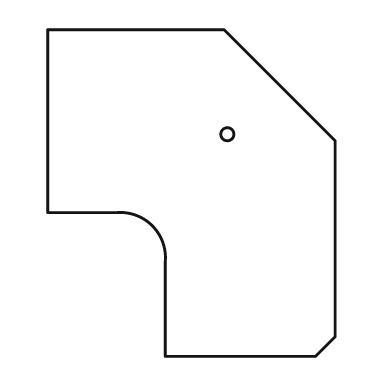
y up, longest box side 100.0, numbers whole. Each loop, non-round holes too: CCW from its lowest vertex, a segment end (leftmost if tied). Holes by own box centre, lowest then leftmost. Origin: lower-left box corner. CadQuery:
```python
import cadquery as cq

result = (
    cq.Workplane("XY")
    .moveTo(36.0, 0.0)
    .lineTo(82.0, 0.0)
    .lineTo(88.0, 6.0)
    .lineTo(88.0, 66.0)
    .lineTo(54.0, 100.0)
    .lineTo(0.0, 100.0)
    .lineTo(0.0, 44.0)
    .lineTo(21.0, 44.0)
    .threePointArc((32.0, 40.0), (36.0, 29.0))
    .close()
    .moveTo(55.0, 68.0)
    .circle(2.0)
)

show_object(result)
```